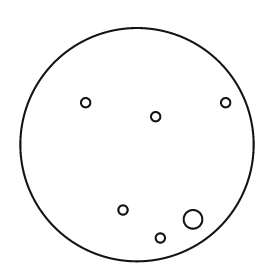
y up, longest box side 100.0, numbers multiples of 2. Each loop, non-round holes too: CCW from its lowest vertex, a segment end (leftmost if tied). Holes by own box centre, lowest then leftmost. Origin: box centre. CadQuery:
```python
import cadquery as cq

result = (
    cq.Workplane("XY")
    .moveTo(0.0, 0.0)
    .circle(50.0)
    .moveTo(10.0, -40.0)
    .circle(2.0)
    .moveTo(24.0, -32.0)
    .circle(4.0)
    .moveTo(-6.0, -28.0)
    .circle(2.0)
    .moveTo(8.0, 12.0)
    .circle(2.0)
    .moveTo(-22.0, 18.0)
    .circle(2.0)
    .moveTo(38.0, 18.0)
    .circle(2.0)
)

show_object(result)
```